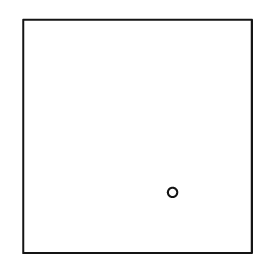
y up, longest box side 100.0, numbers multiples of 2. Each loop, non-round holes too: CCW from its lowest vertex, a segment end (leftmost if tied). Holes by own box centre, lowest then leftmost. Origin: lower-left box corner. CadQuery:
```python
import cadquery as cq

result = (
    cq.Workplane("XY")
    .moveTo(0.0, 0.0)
    .lineTo(98.0, 0.0)
    .lineTo(98.0, 100.0)
    .lineTo(0.0, 100.0)
    .close()
    .moveTo(64.0, 26.0)
    .circle(2.0)
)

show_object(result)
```